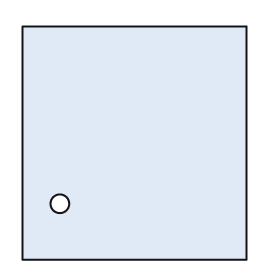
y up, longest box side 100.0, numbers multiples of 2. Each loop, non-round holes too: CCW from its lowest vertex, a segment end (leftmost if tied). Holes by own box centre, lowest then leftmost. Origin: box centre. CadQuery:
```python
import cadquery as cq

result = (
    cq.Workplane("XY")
    .moveTo(-48.0, -50.0)
    .lineTo(48.0, -50.0)
    .lineTo(48.0, 50.0)
    .lineTo(-48.0, 50.0)
    .close()
    .moveTo(-32.0, -26.0)
    .circle(4.0)
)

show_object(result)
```